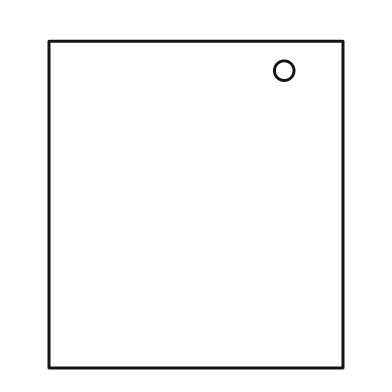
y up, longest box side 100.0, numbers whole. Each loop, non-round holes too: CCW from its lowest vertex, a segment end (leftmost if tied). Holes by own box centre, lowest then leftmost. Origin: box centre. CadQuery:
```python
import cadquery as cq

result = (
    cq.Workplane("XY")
    .moveTo(-45.0, -50.0)
    .lineTo(45.0, -50.0)
    .lineTo(45.0, 50.0)
    .lineTo(-45.0, 50.0)
    .close()
    .moveTo(27.0, 41.0)
    .circle(3.0)
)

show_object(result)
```